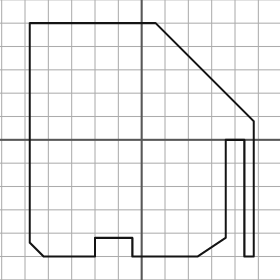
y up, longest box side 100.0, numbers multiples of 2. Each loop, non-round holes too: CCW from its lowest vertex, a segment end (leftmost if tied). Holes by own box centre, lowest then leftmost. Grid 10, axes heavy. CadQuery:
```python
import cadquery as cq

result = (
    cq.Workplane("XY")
    .moveTo(-42.0, -50.0)
    .lineTo(-20.0, -50.0)
    .lineTo(-20.0, -42.0)
    .lineTo(-4.0, -42.0)
    .lineTo(-4.0, -50.0)
    .lineTo(24.0, -50.0)
    .lineTo(36.0, -42.0)
    .lineTo(36.0, 0.0)
    .lineTo(44.0, 0.0)
    .lineTo(44.0, -50.0)
    .lineTo(48.0, -50.0)
    .lineTo(48.0, 8.0)
    .lineTo(6.0, 50.0)
    .lineTo(-48.0, 50.0)
    .lineTo(-48.0, -44.0)
    .close()
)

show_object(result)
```